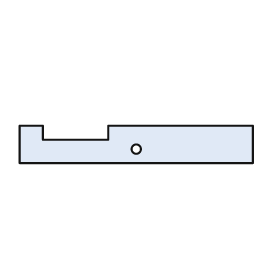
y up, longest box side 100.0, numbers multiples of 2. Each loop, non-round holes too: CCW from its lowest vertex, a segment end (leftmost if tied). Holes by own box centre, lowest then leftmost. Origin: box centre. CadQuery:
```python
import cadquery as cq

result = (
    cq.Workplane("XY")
    .moveTo(-50.0, -8.0)
    .lineTo(50.0, -8.0)
    .lineTo(50.0, 8.0)
    .lineTo(-12.0, 8.0)
    .lineTo(-12.0, 2.0)
    .lineTo(-40.0, 2.0)
    .lineTo(-40.0, 8.0)
    .lineTo(-50.0, 8.0)
    .close()
    .moveTo(0.0, -2.0)
    .circle(2.0)
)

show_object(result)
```